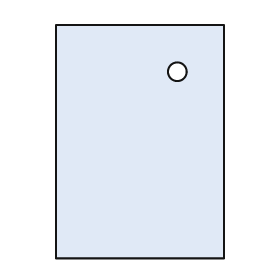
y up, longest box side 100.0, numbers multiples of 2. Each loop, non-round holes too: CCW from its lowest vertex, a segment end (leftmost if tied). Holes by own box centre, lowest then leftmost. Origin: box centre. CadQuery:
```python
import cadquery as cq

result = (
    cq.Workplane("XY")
    .moveTo(-36.0, -50.0)
    .lineTo(36.0, -50.0)
    .lineTo(36.0, 50.0)
    .lineTo(-36.0, 50.0)
    .close()
    .moveTo(16.0, 30.0)
    .circle(4.0)
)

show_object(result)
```